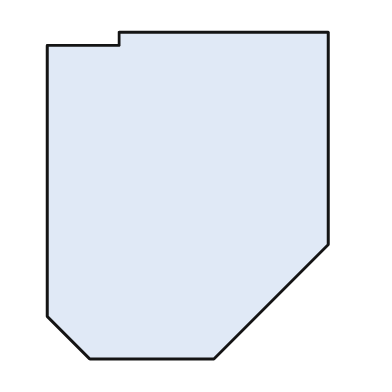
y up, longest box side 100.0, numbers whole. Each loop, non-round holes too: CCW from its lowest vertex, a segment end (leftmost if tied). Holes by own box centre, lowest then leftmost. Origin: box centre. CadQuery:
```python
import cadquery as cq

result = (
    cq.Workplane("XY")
    .moveTo(-30.0, -50.0)
    .lineTo(8.0, -50.0)
    .lineTo(43.0, -15.0)
    .lineTo(43.0, 50.0)
    .lineTo(-21.0, 50.0)
    .lineTo(-21.0, 46.0)
    .lineTo(-43.0, 46.0)
    .lineTo(-43.0, -37.0)
    .close()
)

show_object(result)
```